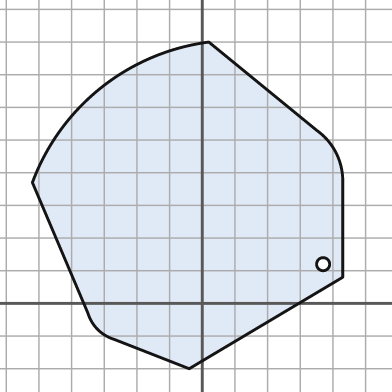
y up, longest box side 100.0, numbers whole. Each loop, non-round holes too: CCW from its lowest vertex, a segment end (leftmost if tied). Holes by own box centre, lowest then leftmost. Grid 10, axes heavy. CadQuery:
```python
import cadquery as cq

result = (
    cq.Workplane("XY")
    .moveTo(-4.0, -20.0)
    .lineTo(43.0, 8.0)
    .lineTo(43.0, 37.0)
    .threePointArc((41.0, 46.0), (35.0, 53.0))
    .lineTo(2.0, 80.0)
    .threePointArc((-31.0, 66.0), (-52.0, 37.0))
    .lineTo(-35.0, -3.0)
    .threePointArc((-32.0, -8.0), (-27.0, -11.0))
    .close()
    .moveTo(37.0, 12.0)
    .circle(2.0)
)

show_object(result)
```